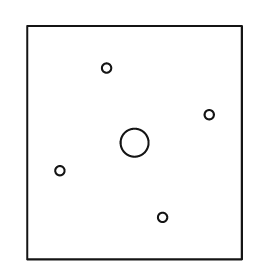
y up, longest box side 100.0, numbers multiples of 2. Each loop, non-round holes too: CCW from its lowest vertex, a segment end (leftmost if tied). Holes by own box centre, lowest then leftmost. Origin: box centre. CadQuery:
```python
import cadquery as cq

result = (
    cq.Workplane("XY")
    .moveTo(-46.0, -50.0)
    .lineTo(46.0, -50.0)
    .lineTo(46.0, 50.0)
    .lineTo(-46.0, 50.0)
    .close()
    .moveTo(12.0, -32.0)
    .circle(2.0)
    .moveTo(-32.0, -12.0)
    .circle(2.0)
    .moveTo(0.0, 0.0)
    .circle(6.0)
    .moveTo(32.0, 12.0)
    .circle(2.0)
    .moveTo(-12.0, 32.0)
    .circle(2.0)
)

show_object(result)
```